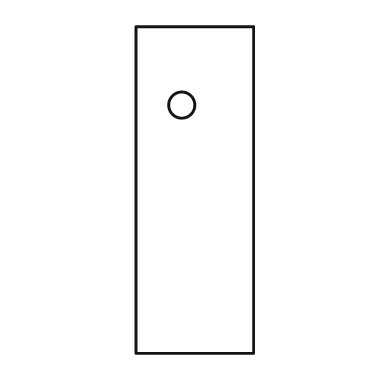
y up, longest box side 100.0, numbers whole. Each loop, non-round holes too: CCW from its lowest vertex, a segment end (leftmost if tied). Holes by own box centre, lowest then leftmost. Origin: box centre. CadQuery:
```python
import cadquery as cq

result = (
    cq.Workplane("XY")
    .moveTo(-18.0, -50.0)
    .lineTo(18.0, -50.0)
    .lineTo(18.0, 50.0)
    .lineTo(-18.0, 50.0)
    .close()
    .moveTo(-4.0, 26.0)
    .circle(4.0)
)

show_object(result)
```